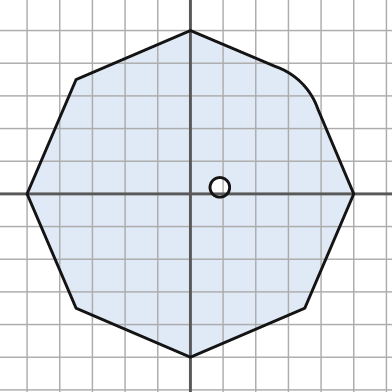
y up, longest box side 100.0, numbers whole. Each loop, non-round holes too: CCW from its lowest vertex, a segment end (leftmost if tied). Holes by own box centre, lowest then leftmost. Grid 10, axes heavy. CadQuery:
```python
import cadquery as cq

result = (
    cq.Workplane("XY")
    .moveTo(0.0, -50.0)
    .lineTo(35.0, -35.0)
    .lineTo(50.0, 0.0)
    .lineTo(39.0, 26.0)
    .threePointArc((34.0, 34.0), (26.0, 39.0))
    .lineTo(0.0, 50.0)
    .lineTo(-35.0, 35.0)
    .lineTo(-50.0, 0.0)
    .lineTo(-35.0, -35.0)
    .close()
    .moveTo(9.0, 2.0)
    .circle(3.0)
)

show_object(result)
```